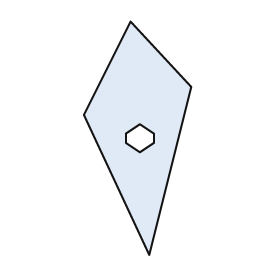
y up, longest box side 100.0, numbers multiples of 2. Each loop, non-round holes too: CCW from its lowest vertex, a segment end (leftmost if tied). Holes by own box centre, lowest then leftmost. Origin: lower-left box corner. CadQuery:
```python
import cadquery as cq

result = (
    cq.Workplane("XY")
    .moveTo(28.0, 0.0)
    .lineTo(46.0, 72.0)
    .lineTo(20.0, 100.0)
    .lineTo(0.0, 60.0)
    .close()
    .moveTo(24.0, 44.0)
    .lineTo(30.0, 48.0)
    .lineTo(30.0, 52.0)
    .lineTo(24.0, 56.0)
    .lineTo(18.0, 52.0)
    .lineTo(18.0, 48.0)
    .close()
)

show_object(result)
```